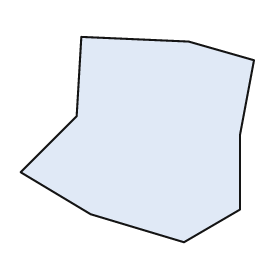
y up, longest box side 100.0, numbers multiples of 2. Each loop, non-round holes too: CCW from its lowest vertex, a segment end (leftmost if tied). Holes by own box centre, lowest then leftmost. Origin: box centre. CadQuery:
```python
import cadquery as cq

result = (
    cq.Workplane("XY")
    .moveTo(20.0, -44.0)
    .lineTo(44.0, -30.0)
    .lineTo(44.0, 2.0)
    .lineTo(50.0, 34.0)
    .lineTo(22.0, 42.0)
    .lineTo(-24.0, 44.0)
    .lineTo(-26.0, 10.0)
    .lineTo(-50.0, -14.0)
    .lineTo(-20.0, -32.0)
    .close()
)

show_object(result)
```